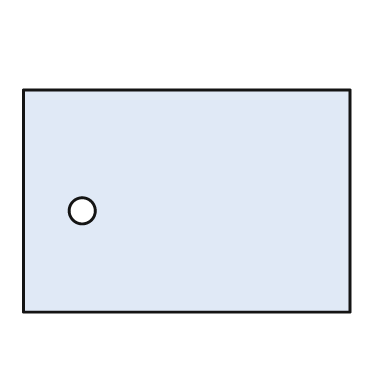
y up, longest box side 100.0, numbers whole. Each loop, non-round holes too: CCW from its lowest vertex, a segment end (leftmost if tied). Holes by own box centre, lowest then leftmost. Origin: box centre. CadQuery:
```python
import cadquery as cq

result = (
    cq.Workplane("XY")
    .moveTo(-50.0, -34.0)
    .lineTo(50.0, -34.0)
    .lineTo(50.0, 34.0)
    .lineTo(-50.0, 34.0)
    .close()
    .moveTo(-32.0, -3.0)
    .circle(4.0)
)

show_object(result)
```